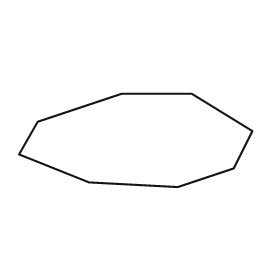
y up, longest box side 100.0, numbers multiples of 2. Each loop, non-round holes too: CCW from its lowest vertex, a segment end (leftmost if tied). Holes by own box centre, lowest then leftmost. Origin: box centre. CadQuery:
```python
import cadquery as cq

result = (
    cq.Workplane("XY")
    .moveTo(18.0, -20.0)
    .lineTo(42.0, -12.0)
    .lineTo(50.0, 4.0)
    .lineTo(24.0, 20.0)
    .lineTo(-6.0, 20.0)
    .lineTo(-42.0, 8.0)
    .lineTo(-50.0, -6.0)
    .lineTo(-20.0, -18.0)
    .close()
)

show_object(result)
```